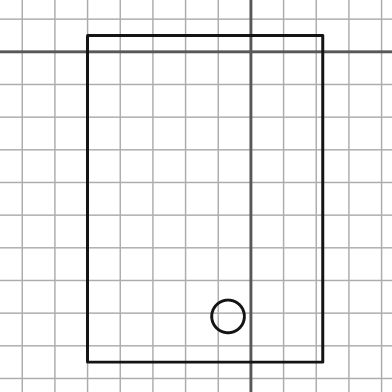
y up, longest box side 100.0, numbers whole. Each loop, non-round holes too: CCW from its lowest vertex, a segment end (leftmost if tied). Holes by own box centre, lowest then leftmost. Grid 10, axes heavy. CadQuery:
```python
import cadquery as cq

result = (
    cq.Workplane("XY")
    .moveTo(-50.0, -95.0)
    .lineTo(22.0, -95.0)
    .lineTo(22.0, 5.0)
    .lineTo(-50.0, 5.0)
    .close()
    .moveTo(-7.0, -81.0)
    .circle(5.0)
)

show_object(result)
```